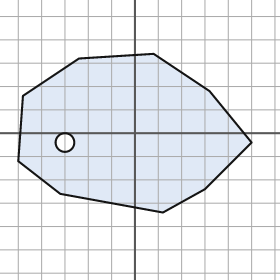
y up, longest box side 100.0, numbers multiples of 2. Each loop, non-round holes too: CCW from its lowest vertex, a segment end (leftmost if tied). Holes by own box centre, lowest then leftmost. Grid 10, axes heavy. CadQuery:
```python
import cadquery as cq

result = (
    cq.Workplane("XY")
    .moveTo(12.0, -34.0)
    .lineTo(30.0, -24.0)
    .lineTo(50.0, -4.0)
    .lineTo(32.0, 18.0)
    .lineTo(8.0, 34.0)
    .lineTo(-24.0, 32.0)
    .lineTo(-48.0, 16.0)
    .lineTo(-50.0, -12.0)
    .lineTo(-32.0, -26.0)
    .close()
    .moveTo(-30.0, -4.0)
    .circle(4.0)
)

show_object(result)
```